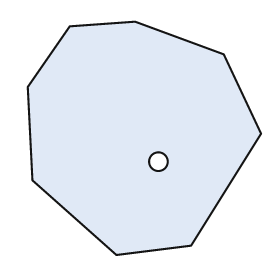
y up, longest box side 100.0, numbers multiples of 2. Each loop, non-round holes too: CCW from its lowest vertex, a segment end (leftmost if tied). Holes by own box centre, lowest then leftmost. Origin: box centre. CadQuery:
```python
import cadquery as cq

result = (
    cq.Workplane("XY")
    .moveTo(-12.0, -50.0)
    .lineTo(20.0, -46.0)
    .lineTo(50.0, 2.0)
    .lineTo(34.0, 36.0)
    .lineTo(-4.0, 50.0)
    .lineTo(-32.0, 48.0)
    .lineTo(-50.0, 22.0)
    .lineTo(-48.0, -18.0)
    .close()
    .moveTo(6.0, -10.0)
    .circle(4.0)
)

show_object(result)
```